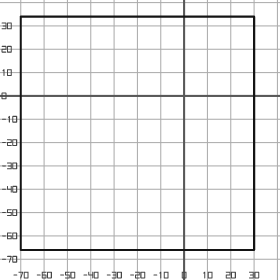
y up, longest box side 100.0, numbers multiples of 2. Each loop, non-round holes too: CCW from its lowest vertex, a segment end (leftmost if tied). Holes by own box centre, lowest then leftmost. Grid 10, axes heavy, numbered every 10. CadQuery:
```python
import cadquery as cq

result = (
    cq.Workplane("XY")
    .moveTo(-70.0, -66.0)
    .lineTo(30.0, -66.0)
    .lineTo(30.0, 34.0)
    .lineTo(-70.0, 34.0)
    .close()
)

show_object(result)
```